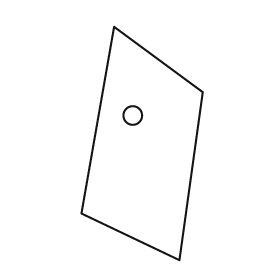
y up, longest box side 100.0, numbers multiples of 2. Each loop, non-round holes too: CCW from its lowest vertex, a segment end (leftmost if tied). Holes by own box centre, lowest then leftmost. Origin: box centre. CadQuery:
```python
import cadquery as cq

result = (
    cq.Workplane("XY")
    .moveTo(16.0, -50.0)
    .lineTo(26.0, 22.0)
    .lineTo(-12.0, 50.0)
    .lineTo(-26.0, -30.0)
    .close()
    .moveTo(-4.0, 12.0)
    .circle(4.0)
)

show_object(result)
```